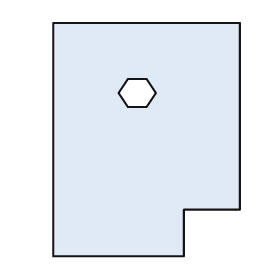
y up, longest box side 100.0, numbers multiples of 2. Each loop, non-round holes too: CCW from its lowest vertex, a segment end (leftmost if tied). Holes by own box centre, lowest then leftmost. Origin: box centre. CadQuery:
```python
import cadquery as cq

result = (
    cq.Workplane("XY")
    .moveTo(-40.0, -50.0)
    .lineTo(16.0, -50.0)
    .lineTo(16.0, -30.0)
    .lineTo(40.0, -30.0)
    .lineTo(40.0, 50.0)
    .lineTo(-40.0, 50.0)
    .close()
    .moveTo(-8.0, 14.0)
    .lineTo(0.0, 14.0)
    .lineTo(4.0, 20.0)
    .lineTo(0.0, 26.0)
    .lineTo(-8.0, 26.0)
    .lineTo(-12.0, 20.0)
    .close()
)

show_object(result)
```